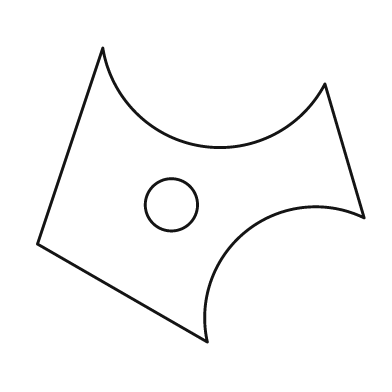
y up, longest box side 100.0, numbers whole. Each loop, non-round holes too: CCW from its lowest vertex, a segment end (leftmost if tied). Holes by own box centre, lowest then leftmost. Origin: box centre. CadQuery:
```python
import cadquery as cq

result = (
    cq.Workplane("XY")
    .moveTo(2.0, -45.0)
    .threePointArc((14.0, -11.0), (50.0, -7.0))
    .lineTo(38.0, 34.0)
    .threePointArc((0.0, 15.0), (-30.0, 45.0))
    .lineTo(-50.0, -15.0)
    .close()
    .moveTo(-9.0, -3.0)
    .circle(8.0)
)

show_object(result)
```